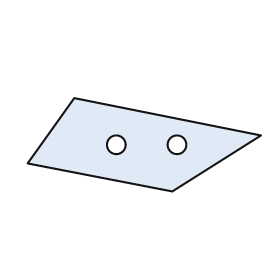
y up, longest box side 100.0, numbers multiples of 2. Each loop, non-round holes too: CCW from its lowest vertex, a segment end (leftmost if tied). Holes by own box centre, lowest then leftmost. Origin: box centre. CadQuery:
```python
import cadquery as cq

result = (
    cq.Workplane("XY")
    .moveTo(12.0, -20.0)
    .lineTo(50.0, 4.0)
    .lineTo(-30.0, 20.0)
    .lineTo(-50.0, -8.0)
    .close()
    .moveTo(-12.0, 0.0)
    .circle(4.0)
    .moveTo(14.0, 0.0)
    .circle(4.0)
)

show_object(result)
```